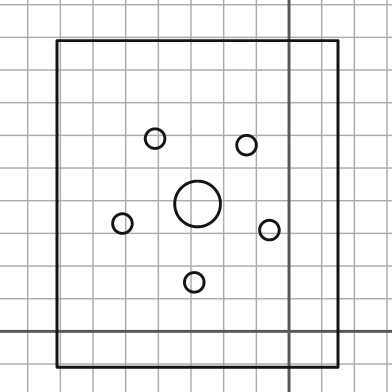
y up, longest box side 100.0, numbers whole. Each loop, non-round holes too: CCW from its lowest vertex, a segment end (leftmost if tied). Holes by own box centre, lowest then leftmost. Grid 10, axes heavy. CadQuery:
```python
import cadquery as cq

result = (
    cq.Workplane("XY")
    .moveTo(-71.0, -11.0)
    .lineTo(15.0, -11.0)
    .lineTo(15.0, 89.0)
    .lineTo(-71.0, 89.0)
    .close()
    .moveTo(-29.0, 15.0)
    .circle(3.0)
    .moveTo(-6.0, 31.0)
    .circle(3.0)
    .moveTo(-51.0, 33.0)
    .circle(3.0)
    .moveTo(-28.0, 39.0)
    .circle(7.0)
    .moveTo(-13.0, 57.0)
    .circle(3.0)
    .moveTo(-41.0, 59.0)
    .circle(3.0)
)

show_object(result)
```